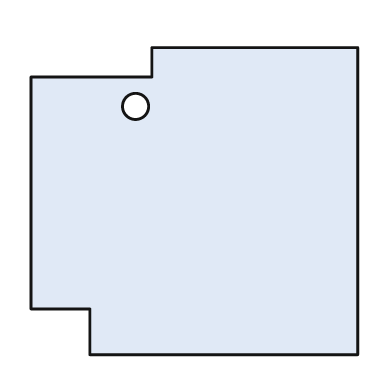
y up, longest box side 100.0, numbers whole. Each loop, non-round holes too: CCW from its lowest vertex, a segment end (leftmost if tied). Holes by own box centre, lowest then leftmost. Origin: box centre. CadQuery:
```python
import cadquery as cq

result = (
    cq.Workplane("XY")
    .moveTo(-32.0, -47.0)
    .lineTo(50.0, -47.0)
    .lineTo(50.0, 47.0)
    .lineTo(-13.0, 47.0)
    .lineTo(-13.0, 38.0)
    .lineTo(-50.0, 38.0)
    .lineTo(-50.0, -33.0)
    .lineTo(-32.0, -33.0)
    .close()
    .moveTo(-18.0, 29.0)
    .circle(4.0)
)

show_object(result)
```